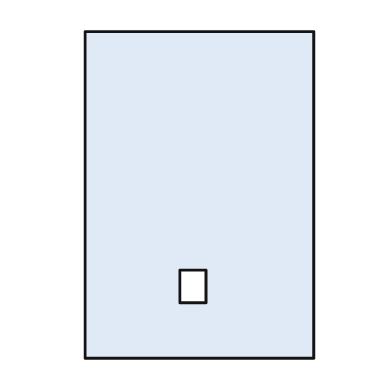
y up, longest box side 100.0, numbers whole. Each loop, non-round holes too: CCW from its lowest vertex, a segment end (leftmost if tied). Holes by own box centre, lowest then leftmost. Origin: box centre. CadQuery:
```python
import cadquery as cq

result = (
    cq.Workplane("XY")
    .moveTo(-35.0, -50.0)
    .lineTo(35.0, -50.0)
    .lineTo(35.0, 50.0)
    .lineTo(-35.0, 50.0)
    .close()
    .moveTo(-6.0, -33.0)
    .lineTo(2.0, -33.0)
    .lineTo(2.0, -23.0)
    .lineTo(-6.0, -23.0)
    .close()
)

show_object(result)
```